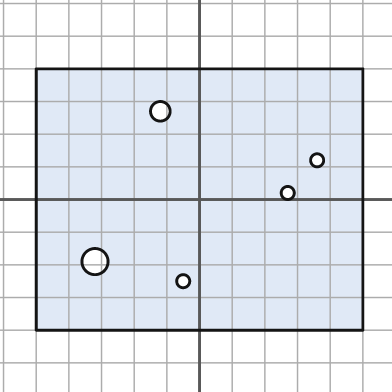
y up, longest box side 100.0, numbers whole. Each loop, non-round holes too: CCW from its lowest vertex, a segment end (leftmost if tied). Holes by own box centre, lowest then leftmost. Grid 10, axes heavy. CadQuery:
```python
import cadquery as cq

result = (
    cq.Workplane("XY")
    .moveTo(-50.0, -40.0)
    .lineTo(50.0, -40.0)
    .lineTo(50.0, 40.0)
    .lineTo(-50.0, 40.0)
    .close()
    .moveTo(-5.0, -25.0)
    .circle(2.0)
    .moveTo(-32.0, -19.0)
    .circle(4.0)
    .moveTo(27.0, 2.0)
    .circle(2.0)
    .moveTo(36.0, 12.0)
    .circle(2.0)
    .moveTo(-12.0, 27.0)
    .circle(3.0)
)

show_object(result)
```